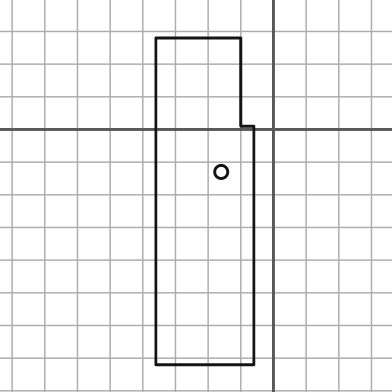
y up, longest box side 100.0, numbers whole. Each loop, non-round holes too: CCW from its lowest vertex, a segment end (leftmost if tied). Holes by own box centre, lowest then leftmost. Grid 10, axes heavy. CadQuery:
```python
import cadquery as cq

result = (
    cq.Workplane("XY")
    .moveTo(-36.0, -72.0)
    .lineTo(-6.0, -72.0)
    .lineTo(-6.0, 1.0)
    .lineTo(-10.0, 1.0)
    .lineTo(-10.0, 28.0)
    .lineTo(-36.0, 28.0)
    .close()
    .moveTo(-16.0, -13.0)
    .circle(2.0)
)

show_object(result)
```